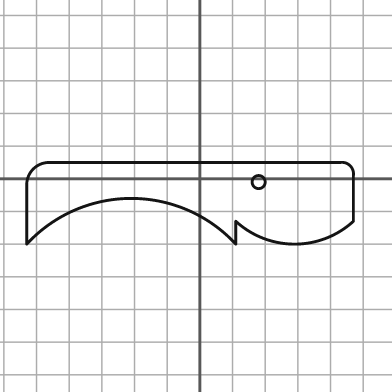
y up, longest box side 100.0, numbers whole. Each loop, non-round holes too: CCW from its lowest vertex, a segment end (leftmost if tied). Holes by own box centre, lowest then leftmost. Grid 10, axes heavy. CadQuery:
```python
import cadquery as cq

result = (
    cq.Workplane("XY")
    .moveTo(-53.0, -20.0)
    .threePointArc((-21.0, -6.0), (11.0, -20.0))
    .lineTo(11.0, -13.0)
    .threePointArc((29.0, -20.0), (47.0, -13.0))
    .lineTo(47.0, 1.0)
    .threePointArc((46.0, 4.0), (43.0, 5.0))
    .lineTo(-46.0, 5.0)
    .threePointArc((-51.0, 3.0), (-53.0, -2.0))
    .close()
    .moveTo(18.0, -1.0)
    .circle(2.0)
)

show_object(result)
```